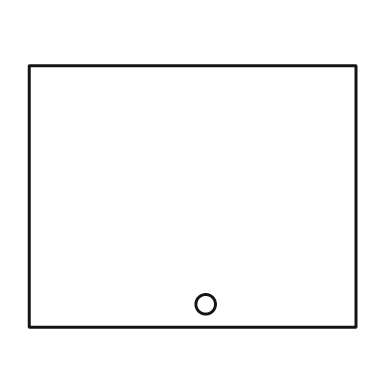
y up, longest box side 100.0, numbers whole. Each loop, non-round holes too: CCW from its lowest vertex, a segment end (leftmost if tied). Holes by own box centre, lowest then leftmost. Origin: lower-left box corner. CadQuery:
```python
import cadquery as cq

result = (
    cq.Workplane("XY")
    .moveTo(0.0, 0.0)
    .lineTo(100.0, 0.0)
    .lineTo(100.0, 80.0)
    .lineTo(0.0, 80.0)
    .close()
    .moveTo(54.0, 7.0)
    .circle(3.0)
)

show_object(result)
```